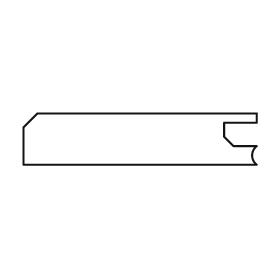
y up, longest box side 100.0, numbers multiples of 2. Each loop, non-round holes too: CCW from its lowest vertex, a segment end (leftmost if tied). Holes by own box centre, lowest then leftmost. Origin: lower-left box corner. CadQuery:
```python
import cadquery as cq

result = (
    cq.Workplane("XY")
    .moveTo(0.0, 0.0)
    .lineTo(100.0, 0.0)
    .threePointArc((98.0, 4.0), (100.0, 8.0))
    .lineTo(90.0, 8.0)
    .lineTo(86.0, 12.0)
    .lineTo(86.0, 18.0)
    .lineTo(100.0, 18.0)
    .lineTo(100.0, 22.0)
    .lineTo(6.0, 22.0)
    .lineTo(0.0, 16.0)
    .close()
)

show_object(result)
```